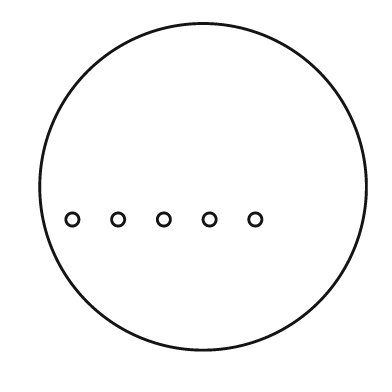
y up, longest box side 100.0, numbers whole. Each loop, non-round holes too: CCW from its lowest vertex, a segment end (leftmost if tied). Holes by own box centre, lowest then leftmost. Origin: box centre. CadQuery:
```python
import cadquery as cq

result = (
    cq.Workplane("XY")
    .moveTo(0.0, 0.0)
    .circle(50.0)
    .moveTo(-40.0, -10.0)
    .circle(2.0)
    .moveTo(-26.0, -10.0)
    .circle(2.0)
    .moveTo(-12.0, -10.0)
    .circle(2.0)
    .moveTo(2.0, -10.0)
    .circle(2.0)
    .moveTo(16.0, -10.0)
    .circle(2.0)
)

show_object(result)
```